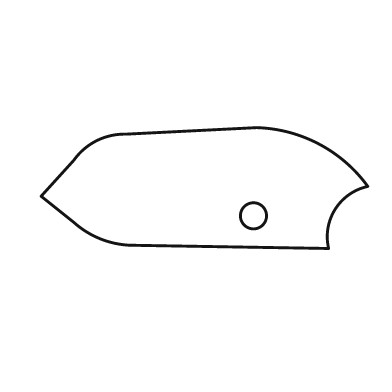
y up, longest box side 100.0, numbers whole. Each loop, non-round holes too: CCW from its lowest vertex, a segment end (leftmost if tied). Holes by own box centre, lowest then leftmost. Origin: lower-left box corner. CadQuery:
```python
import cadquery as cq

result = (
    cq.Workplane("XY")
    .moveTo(88.0, 0.0)
    .threePointArc((90.0, 12.0), (100.0, 19.0))
    .threePointArc((85.0, 32.0), (66.0, 37.0))
    .lineTo(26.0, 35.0)
    .threePointArc((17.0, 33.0), (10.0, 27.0))
    .lineTo(0.0, 16.0)
    .lineTo(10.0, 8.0)
    .threePointArc((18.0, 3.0), (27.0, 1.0))
    .close()
    .moveTo(65.0, 10.0)
    .circle(4.0)
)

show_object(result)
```